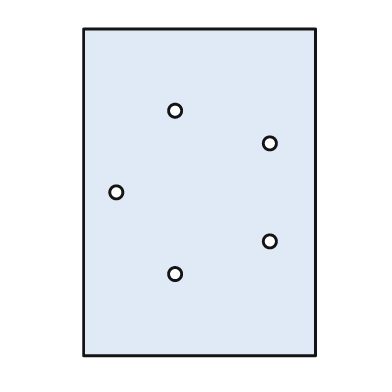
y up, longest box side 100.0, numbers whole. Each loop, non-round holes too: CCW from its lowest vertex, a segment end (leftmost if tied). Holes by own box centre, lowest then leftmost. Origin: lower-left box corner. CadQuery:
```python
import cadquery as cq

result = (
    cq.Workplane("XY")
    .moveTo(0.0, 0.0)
    .lineTo(71.0, 0.0)
    .lineTo(71.0, 100.0)
    .lineTo(0.0, 100.0)
    .close()
    .moveTo(28.0, 25.0)
    .circle(2.0)
    .moveTo(57.0, 35.0)
    .circle(2.0)
    .moveTo(10.0, 50.0)
    .circle(2.0)
    .moveTo(57.0, 65.0)
    .circle(2.0)
    .moveTo(28.0, 75.0)
    .circle(2.0)
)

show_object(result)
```